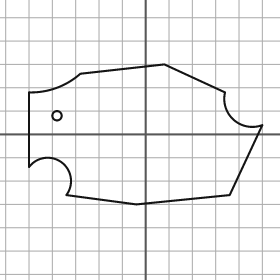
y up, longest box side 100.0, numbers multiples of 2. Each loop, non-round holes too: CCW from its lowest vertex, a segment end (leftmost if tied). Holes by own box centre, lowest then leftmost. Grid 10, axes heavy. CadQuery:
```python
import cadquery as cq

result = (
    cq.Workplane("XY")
    .moveTo(-4.0, -30.0)
    .lineTo(36.0, -26.0)
    .lineTo(50.0, 4.0)
    .threePointArc((38.0, 6.0), (34.0, 18.0))
    .lineTo(8.0, 30.0)
    .lineTo(-28.0, 26.0)
    .threePointArc((-38.0, 20.0), (-50.0, 18.0))
    .lineTo(-50.0, -14.0)
    .threePointArc((-36.0, -12.0), (-34.0, -26.0))
    .close()
    .moveTo(-38.0, 8.0)
    .circle(2.0)
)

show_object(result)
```